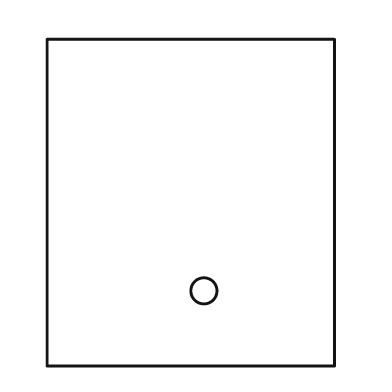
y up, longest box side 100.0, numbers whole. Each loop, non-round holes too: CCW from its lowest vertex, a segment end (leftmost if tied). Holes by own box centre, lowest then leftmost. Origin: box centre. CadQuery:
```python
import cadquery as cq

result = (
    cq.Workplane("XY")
    .moveTo(-44.0, -50.0)
    .lineTo(44.0, -50.0)
    .lineTo(44.0, 50.0)
    .lineTo(-44.0, 50.0)
    .close()
    .moveTo(4.0, -27.0)
    .circle(4.0)
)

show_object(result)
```